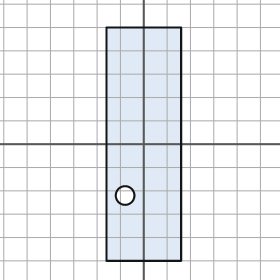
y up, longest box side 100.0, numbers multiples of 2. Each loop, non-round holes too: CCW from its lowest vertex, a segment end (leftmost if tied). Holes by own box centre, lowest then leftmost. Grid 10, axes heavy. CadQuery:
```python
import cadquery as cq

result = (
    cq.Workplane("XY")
    .moveTo(-16.0, -50.0)
    .lineTo(16.0, -50.0)
    .lineTo(16.0, 50.0)
    .lineTo(-16.0, 50.0)
    .close()
    .moveTo(-8.0, -22.0)
    .circle(4.0)
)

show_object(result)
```